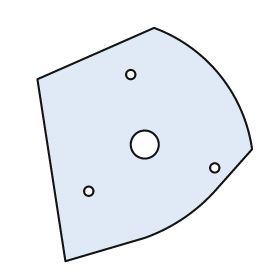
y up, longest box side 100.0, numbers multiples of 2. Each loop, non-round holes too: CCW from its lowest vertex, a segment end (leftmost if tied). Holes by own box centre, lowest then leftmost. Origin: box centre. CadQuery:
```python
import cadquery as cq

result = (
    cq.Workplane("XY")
    .moveTo(-34.0, -50.0)
    .lineTo(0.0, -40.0)
    .threePointArc((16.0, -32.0), (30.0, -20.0))
    .lineTo(46.0, -2.0)
    .threePointArc((32.0, 30.0), (4.0, 50.0))
    .lineTo(-46.0, 28.0)
    .close()
    .moveTo(-24.0, -20.0)
    .circle(2.0)
    .moveTo(30.0, -10.0)
    .circle(2.0)
    .moveTo(0.0, 0.0)
    .circle(6.0)
    .moveTo(-6.0, 30.0)
    .circle(2.0)
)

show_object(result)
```